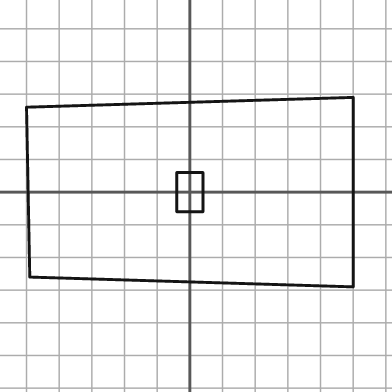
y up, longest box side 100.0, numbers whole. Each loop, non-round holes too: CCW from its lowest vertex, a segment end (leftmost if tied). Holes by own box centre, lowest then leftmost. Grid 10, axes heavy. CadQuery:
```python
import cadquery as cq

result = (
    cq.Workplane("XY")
    .moveTo(50.0, -29.0)
    .lineTo(50.0, 29.0)
    .lineTo(-50.0, 26.0)
    .lineTo(-49.0, -26.0)
    .close()
    .moveTo(-4.0, -6.0)
    .lineTo(4.0, -6.0)
    .lineTo(4.0, 6.0)
    .lineTo(-4.0, 6.0)
    .close()
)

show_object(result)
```